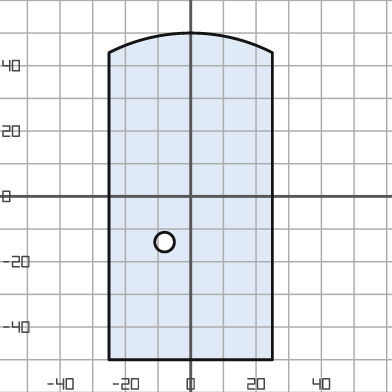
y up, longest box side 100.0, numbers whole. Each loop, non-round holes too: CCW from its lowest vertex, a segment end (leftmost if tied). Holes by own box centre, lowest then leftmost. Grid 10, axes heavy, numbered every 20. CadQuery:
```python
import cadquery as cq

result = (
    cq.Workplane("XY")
    .moveTo(-25.0, -50.0)
    .lineTo(25.0, -50.0)
    .lineTo(25.0, 44.0)
    .threePointArc((0.0, 50.0), (-25.0, 44.0))
    .close()
    .moveTo(-8.0, -14.0)
    .circle(3.0)
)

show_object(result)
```